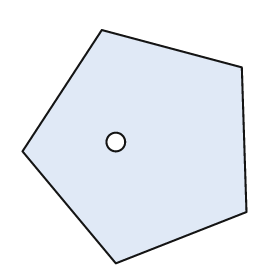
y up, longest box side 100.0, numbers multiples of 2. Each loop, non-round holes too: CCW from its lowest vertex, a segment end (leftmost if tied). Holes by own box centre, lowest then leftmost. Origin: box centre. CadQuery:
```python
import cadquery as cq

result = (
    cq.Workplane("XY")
    .moveTo(-8.0, -50.0)
    .lineTo(48.0, -28.0)
    .lineTo(46.0, 34.0)
    .lineTo(-14.0, 50.0)
    .lineTo(-48.0, -2.0)
    .close()
    .moveTo(-8.0, 2.0)
    .circle(4.0)
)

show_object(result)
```